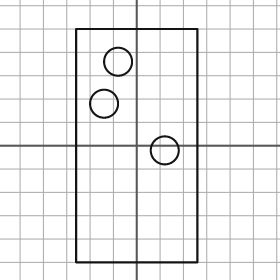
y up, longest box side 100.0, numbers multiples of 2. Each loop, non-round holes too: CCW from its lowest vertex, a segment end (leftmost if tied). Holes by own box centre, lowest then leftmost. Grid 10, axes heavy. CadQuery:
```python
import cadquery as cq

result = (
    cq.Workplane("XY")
    .moveTo(-26.0, -50.0)
    .lineTo(26.0, -50.0)
    .lineTo(26.0, 50.0)
    .lineTo(-26.0, 50.0)
    .close()
    .moveTo(12.0, -2.0)
    .circle(6.0)
    .moveTo(-14.0, 18.0)
    .circle(6.0)
    .moveTo(-8.0, 36.0)
    .circle(6.0)
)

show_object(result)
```